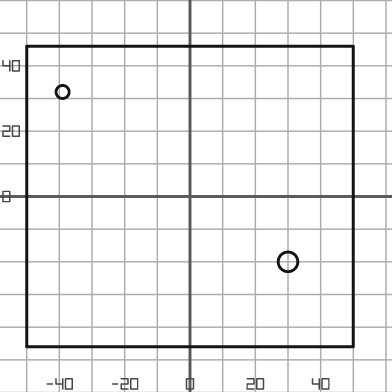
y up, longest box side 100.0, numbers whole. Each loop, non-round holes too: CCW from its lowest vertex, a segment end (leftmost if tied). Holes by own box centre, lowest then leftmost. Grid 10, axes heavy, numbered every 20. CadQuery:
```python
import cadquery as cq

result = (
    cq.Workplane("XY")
    .moveTo(-50.0, -46.0)
    .lineTo(50.0, -46.0)
    .lineTo(50.0, 46.0)
    .lineTo(-50.0, 46.0)
    .close()
    .moveTo(30.0, -20.0)
    .circle(3.0)
    .moveTo(-39.0, 32.0)
    .circle(2.0)
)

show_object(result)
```